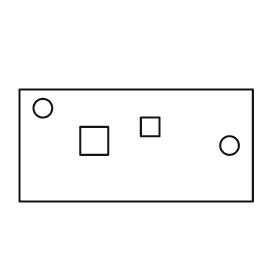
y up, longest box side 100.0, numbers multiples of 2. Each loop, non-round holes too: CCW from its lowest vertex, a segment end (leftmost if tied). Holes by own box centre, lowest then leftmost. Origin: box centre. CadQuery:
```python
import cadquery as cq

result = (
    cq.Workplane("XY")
    .moveTo(-50.0, -24.0)
    .lineTo(50.0, -24.0)
    .lineTo(50.0, 24.0)
    .lineTo(-50.0, 24.0)
    .close()
    .moveTo(40.0, 0.0)
    .circle(4.0)
    .moveTo(-24.0, -4.0)
    .lineTo(-12.0, -4.0)
    .lineTo(-12.0, 8.0)
    .lineTo(-24.0, 8.0)
    .close()
    .moveTo(2.0, 4.0)
    .lineTo(10.0, 4.0)
    .lineTo(10.0, 12.0)
    .lineTo(2.0, 12.0)
    .close()
    .moveTo(-40.0, 16.0)
    .circle(4.0)
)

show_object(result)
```